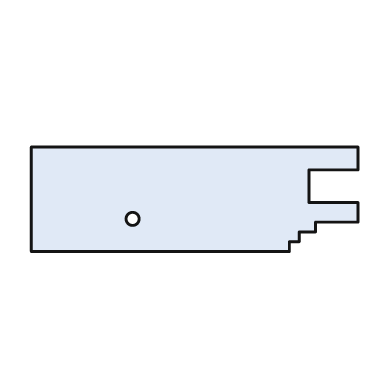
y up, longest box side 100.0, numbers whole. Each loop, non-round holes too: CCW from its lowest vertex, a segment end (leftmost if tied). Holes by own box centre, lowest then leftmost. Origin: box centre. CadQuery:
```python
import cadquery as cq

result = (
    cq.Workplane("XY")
    .moveTo(-50.0, -16.0)
    .lineTo(29.0, -16.0)
    .lineTo(29.0, -13.0)
    .lineTo(32.0, -13.0)
    .lineTo(32.0, -10.0)
    .lineTo(37.0, -10.0)
    .lineTo(37.0, -7.0)
    .lineTo(50.0, -7.0)
    .lineTo(50.0, -1.0)
    .lineTo(35.0, -1.0)
    .lineTo(35.0, 9.0)
    .lineTo(50.0, 9.0)
    .lineTo(50.0, 16.0)
    .lineTo(-50.0, 16.0)
    .close()
    .moveTo(-19.0, -6.0)
    .circle(2.0)
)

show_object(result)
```